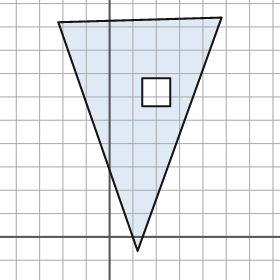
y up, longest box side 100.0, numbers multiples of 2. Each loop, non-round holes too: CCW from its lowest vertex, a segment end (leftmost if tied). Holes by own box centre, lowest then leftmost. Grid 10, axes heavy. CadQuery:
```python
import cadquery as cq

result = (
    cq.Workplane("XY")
    .moveTo(12.0, -6.0)
    .lineTo(48.0, 94.0)
    .lineTo(-22.0, 92.0)
    .close()
    .moveTo(14.0, 56.0)
    .lineTo(26.0, 56.0)
    .lineTo(26.0, 68.0)
    .lineTo(14.0, 68.0)
    .close()
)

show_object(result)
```